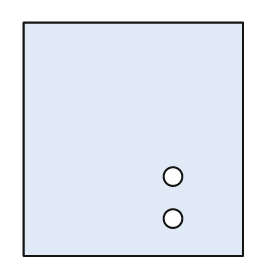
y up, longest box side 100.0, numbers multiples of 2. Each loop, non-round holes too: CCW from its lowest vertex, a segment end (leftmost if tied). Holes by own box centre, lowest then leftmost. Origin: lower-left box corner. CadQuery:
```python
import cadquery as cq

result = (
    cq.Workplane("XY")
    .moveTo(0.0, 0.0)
    .lineTo(94.0, 0.0)
    .lineTo(94.0, 100.0)
    .lineTo(0.0, 100.0)
    .close()
    .moveTo(64.0, 16.0)
    .circle(4.0)
    .moveTo(64.0, 34.0)
    .circle(4.0)
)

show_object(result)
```